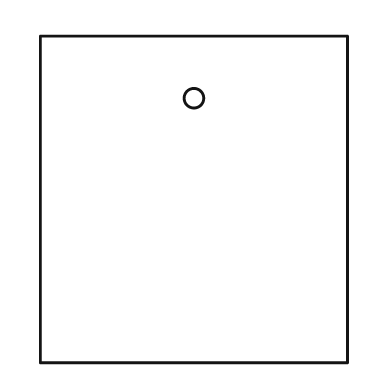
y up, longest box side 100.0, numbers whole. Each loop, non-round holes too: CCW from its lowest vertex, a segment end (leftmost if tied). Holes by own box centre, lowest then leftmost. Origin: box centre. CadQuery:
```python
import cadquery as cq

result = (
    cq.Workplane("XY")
    .moveTo(-47.0, -50.0)
    .lineTo(47.0, -50.0)
    .lineTo(47.0, 50.0)
    .lineTo(-47.0, 50.0)
    .close()
    .moveTo(0.0, 31.0)
    .circle(3.0)
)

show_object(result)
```